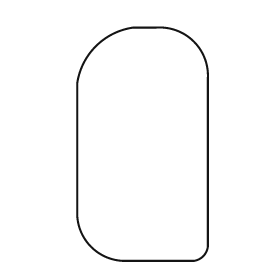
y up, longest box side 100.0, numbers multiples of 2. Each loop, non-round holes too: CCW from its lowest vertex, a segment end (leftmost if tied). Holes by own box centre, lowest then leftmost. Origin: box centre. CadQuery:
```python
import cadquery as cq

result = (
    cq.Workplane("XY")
    .moveTo(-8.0, -50.0)
    .lineTo(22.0, -50.0)
    .threePointArc((26.0, -48.0), (28.0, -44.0))
    .lineTo(28.0, 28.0)
    .threePointArc((22.0, 44.0), (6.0, 50.0))
    .lineTo(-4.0, 50.0)
    .threePointArc((-20.0, 42.0), (-28.0, 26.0))
    .lineTo(-28.0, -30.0)
    .threePointArc((-22.0, -44.0), (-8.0, -50.0))
    .close()
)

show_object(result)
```